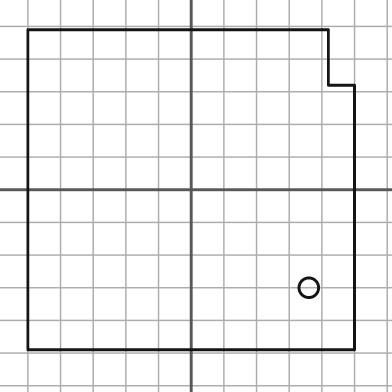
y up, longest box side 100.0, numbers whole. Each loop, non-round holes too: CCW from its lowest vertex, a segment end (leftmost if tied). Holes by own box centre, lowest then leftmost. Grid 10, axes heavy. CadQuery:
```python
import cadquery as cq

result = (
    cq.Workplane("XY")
    .moveTo(-50.0, -49.0)
    .lineTo(50.0, -49.0)
    .lineTo(50.0, 32.0)
    .lineTo(42.0, 32.0)
    .lineTo(42.0, 49.0)
    .lineTo(-50.0, 49.0)
    .close()
    .moveTo(36.0, -30.0)
    .circle(3.0)
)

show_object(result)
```